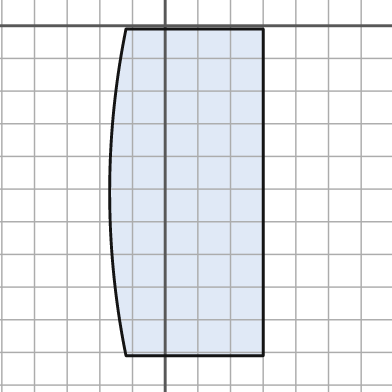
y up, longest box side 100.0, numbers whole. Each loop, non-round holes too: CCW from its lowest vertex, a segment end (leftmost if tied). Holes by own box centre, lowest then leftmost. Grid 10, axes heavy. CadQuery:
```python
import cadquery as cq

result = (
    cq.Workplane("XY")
    .moveTo(-12.0, -101.0)
    .lineTo(30.0, -101.0)
    .lineTo(30.0, -1.0)
    .lineTo(-12.0, -1.0)
    .threePointArc((-17.0, -51.0), (-12.0, -101.0))
    .close()
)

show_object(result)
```